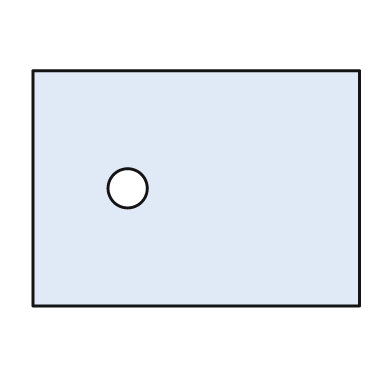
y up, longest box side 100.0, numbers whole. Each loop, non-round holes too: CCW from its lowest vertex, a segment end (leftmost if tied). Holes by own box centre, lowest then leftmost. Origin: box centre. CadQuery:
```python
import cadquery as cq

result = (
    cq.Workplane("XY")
    .moveTo(-50.0, -36.0)
    .lineTo(50.0, -36.0)
    .lineTo(50.0, 36.0)
    .lineTo(-50.0, 36.0)
    .close()
    .moveTo(-21.0, 0.0)
    .circle(6.0)
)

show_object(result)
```